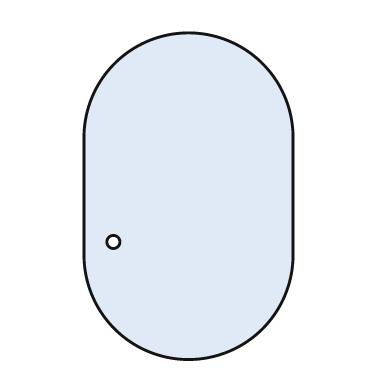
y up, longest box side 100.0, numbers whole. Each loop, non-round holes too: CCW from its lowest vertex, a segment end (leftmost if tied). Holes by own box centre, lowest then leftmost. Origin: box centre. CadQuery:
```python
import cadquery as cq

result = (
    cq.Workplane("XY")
    .moveTo(-32.0, -18.0)
    .threePointArc((0.0, -50.0), (32.0, -18.0))
    .lineTo(32.0, 18.0)
    .threePointArc((0.0, 50.0), (-32.0, 18.0))
    .close()
    .moveTo(-23.0, -14.0)
    .circle(2.0)
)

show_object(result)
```